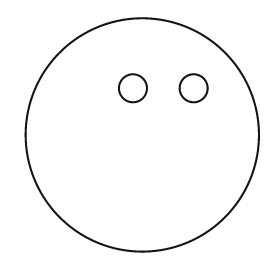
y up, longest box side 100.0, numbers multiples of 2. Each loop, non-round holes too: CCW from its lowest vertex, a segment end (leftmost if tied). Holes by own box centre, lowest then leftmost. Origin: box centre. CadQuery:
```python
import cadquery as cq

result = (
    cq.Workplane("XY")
    .moveTo(0.0, 0.0)
    .circle(50.0)
    .moveTo(-4.0, 20.0)
    .circle(6.0)
    .moveTo(22.0, 20.0)
    .circle(6.0)
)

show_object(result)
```